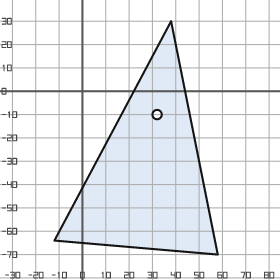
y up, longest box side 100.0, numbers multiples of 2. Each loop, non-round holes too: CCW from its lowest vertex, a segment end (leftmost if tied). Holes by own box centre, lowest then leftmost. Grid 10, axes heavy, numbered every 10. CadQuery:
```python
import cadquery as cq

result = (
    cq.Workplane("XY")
    .moveTo(58.0, -70.0)
    .lineTo(38.0, 30.0)
    .lineTo(-12.0, -64.0)
    .close()
    .moveTo(32.0, -10.0)
    .circle(2.0)
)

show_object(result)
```